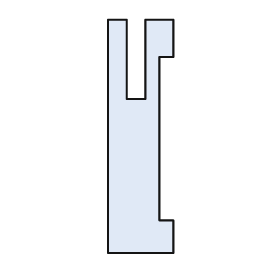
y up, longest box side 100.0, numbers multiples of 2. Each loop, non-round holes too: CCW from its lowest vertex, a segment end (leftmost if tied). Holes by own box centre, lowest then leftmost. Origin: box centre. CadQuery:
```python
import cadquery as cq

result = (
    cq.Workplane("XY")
    .moveTo(-14.0, -50.0)
    .lineTo(14.0, -50.0)
    .lineTo(14.0, -36.0)
    .lineTo(8.0, -36.0)
    .lineTo(8.0, 34.0)
    .lineTo(14.0, 34.0)
    .lineTo(14.0, 50.0)
    .lineTo(2.0, 50.0)
    .lineTo(2.0, 16.0)
    .lineTo(-6.0, 16.0)
    .lineTo(-6.0, 50.0)
    .lineTo(-14.0, 50.0)
    .close()
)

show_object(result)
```